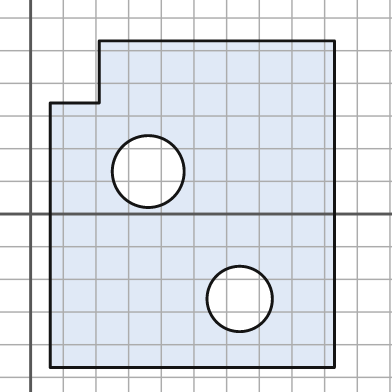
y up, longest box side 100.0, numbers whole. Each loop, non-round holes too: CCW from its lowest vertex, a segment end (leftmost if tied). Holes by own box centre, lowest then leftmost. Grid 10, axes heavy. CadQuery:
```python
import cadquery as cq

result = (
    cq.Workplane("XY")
    .moveTo(6.0, -47.0)
    .lineTo(93.0, -47.0)
    .lineTo(93.0, 53.0)
    .lineTo(21.0, 53.0)
    .lineTo(21.0, 34.0)
    .lineTo(6.0, 34.0)
    .close()
    .moveTo(64.0, -26.0)
    .circle(10.0)
    .moveTo(36.0, 13.0)
    .circle(11.0)
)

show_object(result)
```